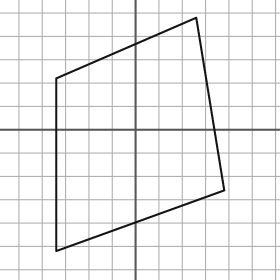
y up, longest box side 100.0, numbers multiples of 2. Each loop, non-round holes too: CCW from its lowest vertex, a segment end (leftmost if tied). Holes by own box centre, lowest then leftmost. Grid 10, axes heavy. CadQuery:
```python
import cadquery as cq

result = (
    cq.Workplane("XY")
    .moveTo(-34.0, -52.0)
    .lineTo(38.0, -26.0)
    .lineTo(26.0, 48.0)
    .lineTo(-34.0, 22.0)
    .close()
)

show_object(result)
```